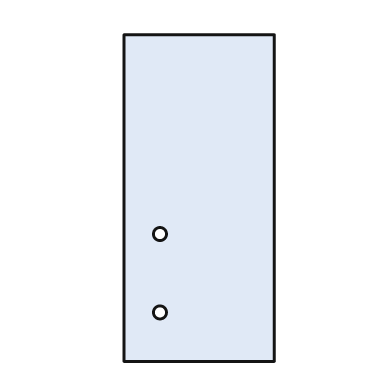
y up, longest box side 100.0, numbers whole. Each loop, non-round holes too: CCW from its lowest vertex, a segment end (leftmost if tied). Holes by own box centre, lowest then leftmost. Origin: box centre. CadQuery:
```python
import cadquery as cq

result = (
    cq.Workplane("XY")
    .moveTo(-23.0, -50.0)
    .lineTo(23.0, -50.0)
    .lineTo(23.0, 50.0)
    .lineTo(-23.0, 50.0)
    .close()
    .moveTo(-12.0, -35.0)
    .circle(2.0)
    .moveTo(-12.0, -11.0)
    .circle(2.0)
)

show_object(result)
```